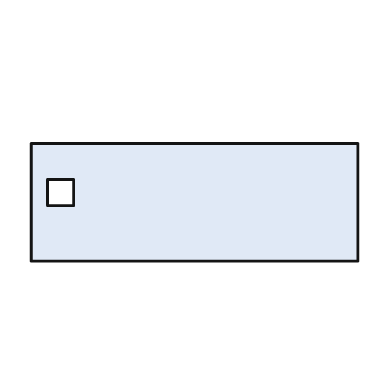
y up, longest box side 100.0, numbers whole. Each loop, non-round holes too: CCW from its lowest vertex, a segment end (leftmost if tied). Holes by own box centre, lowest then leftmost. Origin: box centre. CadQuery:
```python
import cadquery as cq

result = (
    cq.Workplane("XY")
    .moveTo(-50.0, -18.0)
    .lineTo(50.0, -18.0)
    .lineTo(50.0, 18.0)
    .lineTo(-50.0, 18.0)
    .close()
    .moveTo(-45.0, -1.0)
    .lineTo(-37.0, -1.0)
    .lineTo(-37.0, 7.0)
    .lineTo(-45.0, 7.0)
    .close()
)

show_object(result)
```